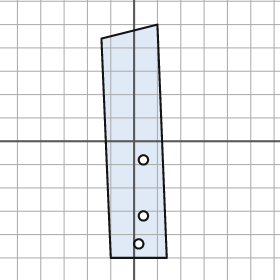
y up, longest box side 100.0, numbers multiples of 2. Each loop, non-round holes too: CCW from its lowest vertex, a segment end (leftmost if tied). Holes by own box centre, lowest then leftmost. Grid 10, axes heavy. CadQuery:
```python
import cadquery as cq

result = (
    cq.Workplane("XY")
    .moveTo(-10.0, -50.0)
    .lineTo(14.0, -50.0)
    .lineTo(10.0, 50.0)
    .lineTo(-14.0, 44.0)
    .close()
    .moveTo(2.0, -44.0)
    .circle(2.0)
    .moveTo(4.0, -32.0)
    .circle(2.0)
    .moveTo(4.0, -8.0)
    .circle(2.0)
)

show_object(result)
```